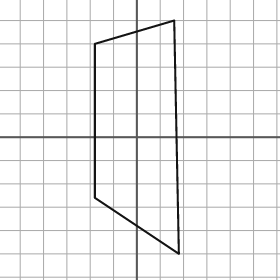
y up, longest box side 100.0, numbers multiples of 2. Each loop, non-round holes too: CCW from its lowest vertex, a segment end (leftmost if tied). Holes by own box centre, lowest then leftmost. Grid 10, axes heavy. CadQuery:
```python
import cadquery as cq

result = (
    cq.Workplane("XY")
    .moveTo(18.0, -50.0)
    .lineTo(16.0, 50.0)
    .lineTo(-18.0, 40.0)
    .lineTo(-18.0, -26.0)
    .close()
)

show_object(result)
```